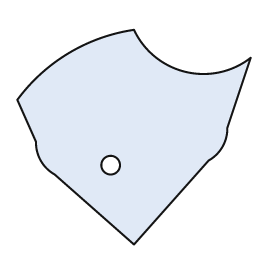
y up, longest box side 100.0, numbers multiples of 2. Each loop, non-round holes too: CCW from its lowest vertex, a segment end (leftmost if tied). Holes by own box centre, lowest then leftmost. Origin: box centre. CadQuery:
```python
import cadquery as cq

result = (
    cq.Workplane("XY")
    .moveTo(0.0, -46.0)
    .lineTo(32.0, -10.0)
    .threePointArc((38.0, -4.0), (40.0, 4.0))
    .lineTo(50.0, 34.0)
    .threePointArc((22.0, 28.0), (0.0, 46.0))
    .threePointArc((-28.0, 36.0), (-50.0, 16.0))
    .lineTo(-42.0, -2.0)
    .threePointArc((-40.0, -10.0), (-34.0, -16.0))
    .close()
    .moveTo(-10.0, -12.0)
    .circle(4.0)
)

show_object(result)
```